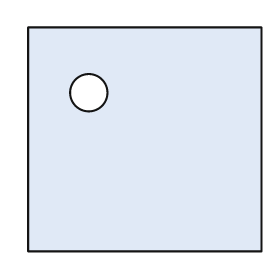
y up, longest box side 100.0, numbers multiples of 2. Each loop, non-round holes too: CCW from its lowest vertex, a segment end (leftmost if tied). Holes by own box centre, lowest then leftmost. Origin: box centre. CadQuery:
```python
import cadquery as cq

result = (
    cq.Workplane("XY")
    .moveTo(-50.0, -48.0)
    .lineTo(50.0, -48.0)
    .lineTo(50.0, 48.0)
    .lineTo(-50.0, 48.0)
    .close()
    .moveTo(-24.0, 20.0)
    .circle(8.0)
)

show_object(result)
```